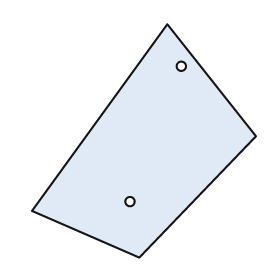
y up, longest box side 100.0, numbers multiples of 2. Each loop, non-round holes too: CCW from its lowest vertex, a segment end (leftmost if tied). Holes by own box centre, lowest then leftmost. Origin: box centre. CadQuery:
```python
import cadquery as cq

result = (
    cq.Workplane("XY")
    .moveTo(-2.0, -50.0)
    .lineTo(48.0, 2.0)
    .lineTo(10.0, 50.0)
    .lineTo(-48.0, -30.0)
    .close()
    .moveTo(-6.0, -26.0)
    .circle(2.0)
    .moveTo(16.0, 32.0)
    .circle(2.0)
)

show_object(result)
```